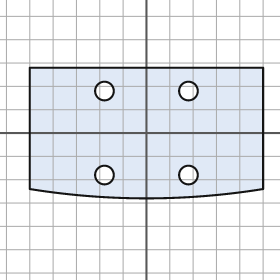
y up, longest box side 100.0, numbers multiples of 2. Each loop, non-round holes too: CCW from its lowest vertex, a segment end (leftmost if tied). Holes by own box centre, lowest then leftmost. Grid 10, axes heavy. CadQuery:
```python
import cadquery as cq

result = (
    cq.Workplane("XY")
    .moveTo(-50.0, -24.0)
    .threePointArc((0.0, -28.0), (50.0, -24.0))
    .lineTo(50.0, 28.0)
    .lineTo(-50.0, 28.0)
    .close()
    .moveTo(-18.0, -18.0)
    .circle(4.0)
    .moveTo(18.0, -18.0)
    .circle(4.0)
    .moveTo(-18.0, 18.0)
    .circle(4.0)
    .moveTo(18.0, 18.0)
    .circle(4.0)
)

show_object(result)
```